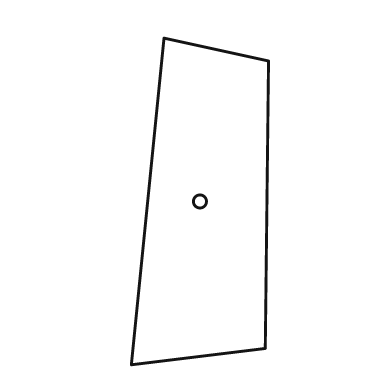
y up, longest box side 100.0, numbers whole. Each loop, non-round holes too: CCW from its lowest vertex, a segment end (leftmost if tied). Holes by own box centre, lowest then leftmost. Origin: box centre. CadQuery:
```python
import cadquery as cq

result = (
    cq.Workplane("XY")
    .moveTo(-21.0, -50.0)
    .lineTo(20.0, -45.0)
    .lineTo(21.0, 43.0)
    .lineTo(-11.0, 50.0)
    .close()
    .moveTo(0.0, 0.0)
    .circle(2.0)
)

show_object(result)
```